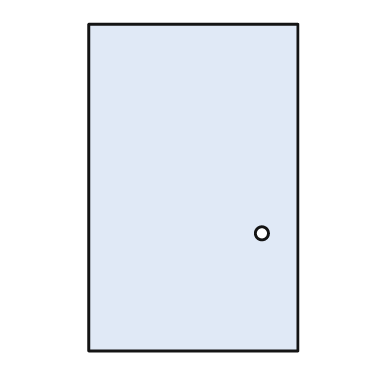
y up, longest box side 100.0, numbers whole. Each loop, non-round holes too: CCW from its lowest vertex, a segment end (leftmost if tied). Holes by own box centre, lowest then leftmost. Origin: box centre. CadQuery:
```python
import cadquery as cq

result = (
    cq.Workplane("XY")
    .moveTo(-32.0, -50.0)
    .lineTo(32.0, -50.0)
    .lineTo(32.0, 50.0)
    .lineTo(-32.0, 50.0)
    .close()
    .moveTo(21.0, -14.0)
    .circle(2.0)
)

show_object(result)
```